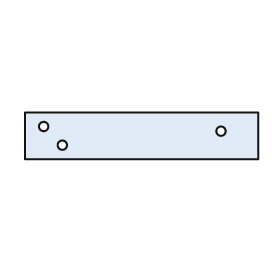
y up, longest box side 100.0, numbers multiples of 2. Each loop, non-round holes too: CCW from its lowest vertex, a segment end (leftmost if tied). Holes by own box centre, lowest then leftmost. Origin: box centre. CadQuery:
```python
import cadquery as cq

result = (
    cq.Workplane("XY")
    .moveTo(-50.0, -10.0)
    .lineTo(50.0, -10.0)
    .lineTo(50.0, 10.0)
    .lineTo(-50.0, 10.0)
    .close()
    .moveTo(-34.0, -4.0)
    .circle(2.0)
    .moveTo(34.0, 2.0)
    .circle(2.0)
    .moveTo(-42.0, 4.0)
    .circle(2.0)
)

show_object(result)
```